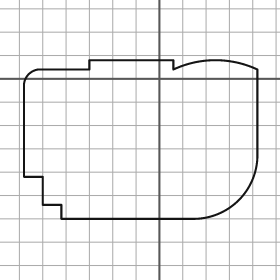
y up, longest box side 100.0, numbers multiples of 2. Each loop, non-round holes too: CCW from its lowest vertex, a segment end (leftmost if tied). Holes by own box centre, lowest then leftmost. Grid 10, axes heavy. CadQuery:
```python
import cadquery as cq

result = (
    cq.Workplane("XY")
    .moveTo(-42.0, -60.0)
    .lineTo(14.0, -60.0)
    .threePointArc((34.0, -52.0), (42.0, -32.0))
    .lineTo(42.0, 4.0)
    .threePointArc((24.0, 8.0), (6.0, 4.0))
    .lineTo(6.0, 8.0)
    .lineTo(-30.0, 8.0)
    .lineTo(-30.0, 4.0)
    .lineTo(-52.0, 4.0)
    .threePointArc((-56.0, 2.0), (-58.0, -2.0))
    .lineTo(-58.0, -42.0)
    .lineTo(-50.0, -42.0)
    .lineTo(-50.0, -54.0)
    .lineTo(-42.0, -54.0)
    .close()
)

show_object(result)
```